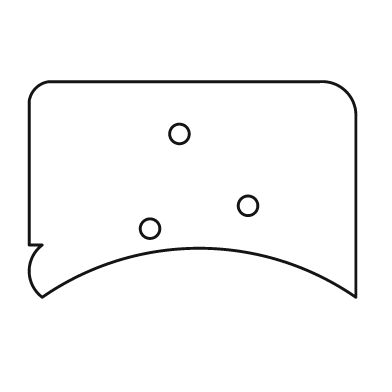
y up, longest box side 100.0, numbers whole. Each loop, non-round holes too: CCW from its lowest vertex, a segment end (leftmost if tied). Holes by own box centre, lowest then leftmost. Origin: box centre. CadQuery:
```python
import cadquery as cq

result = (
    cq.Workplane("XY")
    .moveTo(-46.0, -33.0)
    .threePointArc((2.0, -18.0), (50.0, -33.0))
    .lineTo(50.0, 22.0)
    .threePointArc((47.0, 30.0), (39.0, 33.0))
    .lineTo(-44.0, 33.0)
    .threePointArc((-48.0, 31.0), (-50.0, 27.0))
    .lineTo(-50.0, -17.0)
    .lineTo(-46.0, -17.0)
    .threePointArc((-50.0, -25.0), (-46.0, -33.0))
    .close()
    .moveTo(-13.0, -12.0)
    .circle(3.0)
    .moveTo(17.0, -5.0)
    .circle(3.0)
    .moveTo(-4.0, 17.0)
    .circle(3.0)
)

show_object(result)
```